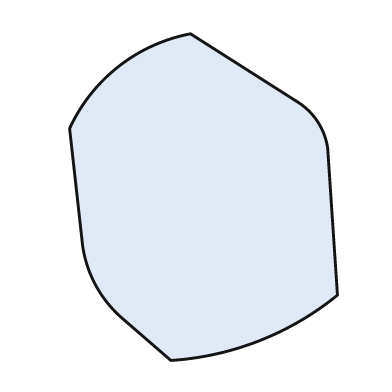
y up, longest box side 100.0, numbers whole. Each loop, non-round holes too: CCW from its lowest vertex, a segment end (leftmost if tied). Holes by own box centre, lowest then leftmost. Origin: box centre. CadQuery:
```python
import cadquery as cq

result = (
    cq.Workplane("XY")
    .moveTo(-10.0, -50.0)
    .threePointArc((17.0, -44.0), (41.0, -30.0))
    .lineTo(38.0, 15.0)
    .threePointArc((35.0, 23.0), (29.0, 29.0))
    .lineTo(-4.0, 50.0)
    .threePointArc((-26.0, 40.0), (-41.0, 21.0))
    .lineTo(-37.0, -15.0)
    .threePointArc((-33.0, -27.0), (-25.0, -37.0))
    .close()
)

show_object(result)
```